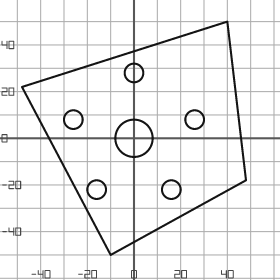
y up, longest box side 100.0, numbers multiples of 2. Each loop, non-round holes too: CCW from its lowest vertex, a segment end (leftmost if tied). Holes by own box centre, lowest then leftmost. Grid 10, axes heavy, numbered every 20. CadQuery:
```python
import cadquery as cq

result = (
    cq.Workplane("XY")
    .moveTo(-10.0, -50.0)
    .lineTo(48.0, -18.0)
    .lineTo(40.0, 50.0)
    .lineTo(-48.0, 22.0)
    .close()
    .moveTo(-16.0, -22.0)
    .circle(4.0)
    .moveTo(16.0, -22.0)
    .circle(4.0)
    .moveTo(0.0, 0.0)
    .circle(8.0)
    .moveTo(-26.0, 8.0)
    .circle(4.0)
    .moveTo(26.0, 8.0)
    .circle(4.0)
    .moveTo(0.0, 28.0)
    .circle(4.0)
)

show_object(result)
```